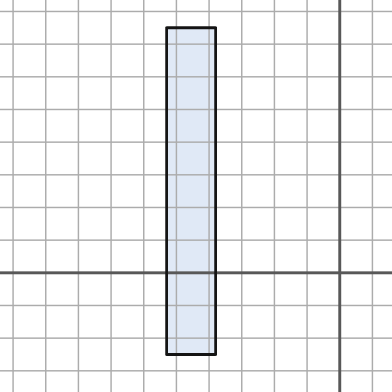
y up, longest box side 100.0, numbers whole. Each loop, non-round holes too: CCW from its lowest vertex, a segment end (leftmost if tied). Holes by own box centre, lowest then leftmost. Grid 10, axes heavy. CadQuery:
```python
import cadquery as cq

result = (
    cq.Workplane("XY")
    .moveTo(-53.0, -25.0)
    .lineTo(-38.0, -25.0)
    .lineTo(-38.0, 75.0)
    .lineTo(-53.0, 75.0)
    .close()
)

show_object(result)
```